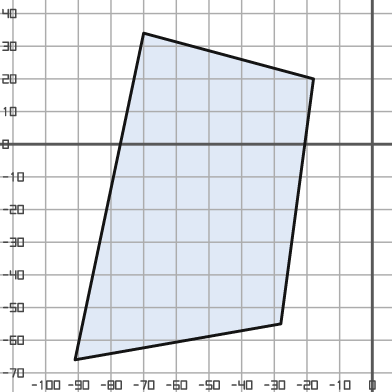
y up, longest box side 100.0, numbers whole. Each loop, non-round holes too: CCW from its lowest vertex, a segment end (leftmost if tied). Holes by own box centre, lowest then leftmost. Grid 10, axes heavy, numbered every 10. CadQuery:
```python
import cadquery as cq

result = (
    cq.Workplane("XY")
    .moveTo(-91.0, -66.0)
    .lineTo(-28.0, -55.0)
    .lineTo(-18.0, 20.0)
    .lineTo(-70.0, 34.0)
    .close()
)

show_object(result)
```